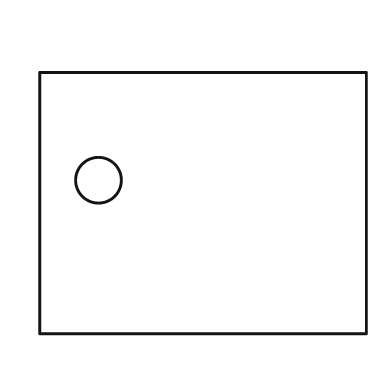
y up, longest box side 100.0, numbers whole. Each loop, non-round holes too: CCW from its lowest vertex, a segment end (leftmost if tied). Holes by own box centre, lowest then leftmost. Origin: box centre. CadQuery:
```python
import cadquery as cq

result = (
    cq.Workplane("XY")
    .moveTo(-50.0, -40.0)
    .lineTo(50.0, -40.0)
    .lineTo(50.0, 40.0)
    .lineTo(-50.0, 40.0)
    .close()
    .moveTo(-32.0, 7.0)
    .circle(7.0)
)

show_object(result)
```